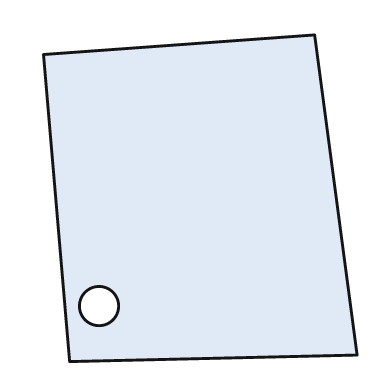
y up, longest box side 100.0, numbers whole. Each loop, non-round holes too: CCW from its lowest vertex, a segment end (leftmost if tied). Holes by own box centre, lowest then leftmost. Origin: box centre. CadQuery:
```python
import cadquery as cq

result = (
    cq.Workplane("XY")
    .moveTo(-40.0, -50.0)
    .lineTo(48.0, -48.0)
    .lineTo(35.0, 50.0)
    .lineTo(-48.0, 44.0)
    .close()
    .moveTo(-31.0, -33.0)
    .circle(6.0)
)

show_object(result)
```